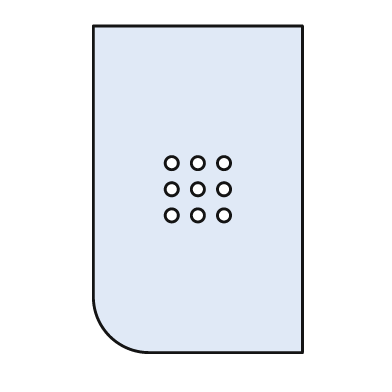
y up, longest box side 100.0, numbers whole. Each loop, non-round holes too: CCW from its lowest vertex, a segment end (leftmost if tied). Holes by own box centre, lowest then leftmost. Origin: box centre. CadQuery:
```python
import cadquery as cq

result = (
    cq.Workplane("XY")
    .moveTo(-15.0, -50.0)
    .lineTo(32.0, -50.0)
    .lineTo(32.0, 50.0)
    .lineTo(-32.0, 50.0)
    .lineTo(-32.0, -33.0)
    .threePointArc((-27.0, -45.0), (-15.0, -50.0))
    .close()
    .moveTo(-8.0, -8.0)
    .circle(2.0)
    .moveTo(0.0, -8.0)
    .circle(2.0)
    .moveTo(8.0, -8.0)
    .circle(2.0)
    .moveTo(-8.0, 0.0)
    .circle(2.0)
    .moveTo(0.0, 0.0)
    .circle(2.0)
    .moveTo(8.0, 0.0)
    .circle(2.0)
    .moveTo(-8.0, 8.0)
    .circle(2.0)
    .moveTo(0.0, 8.0)
    .circle(2.0)
    .moveTo(8.0, 8.0)
    .circle(2.0)
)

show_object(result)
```